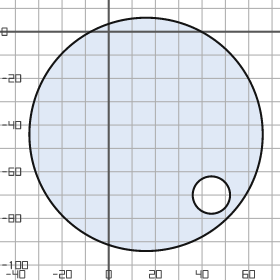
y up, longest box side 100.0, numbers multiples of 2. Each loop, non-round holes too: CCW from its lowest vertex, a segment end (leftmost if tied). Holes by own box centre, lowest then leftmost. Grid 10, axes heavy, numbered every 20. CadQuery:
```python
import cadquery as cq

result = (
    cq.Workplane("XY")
    .moveTo(16.0, -44.0)
    .circle(50.0)
    .moveTo(44.0, -70.0)
    .circle(8.0)
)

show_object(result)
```